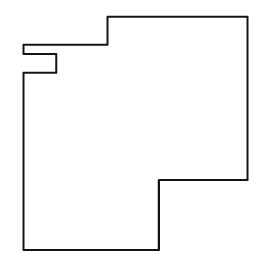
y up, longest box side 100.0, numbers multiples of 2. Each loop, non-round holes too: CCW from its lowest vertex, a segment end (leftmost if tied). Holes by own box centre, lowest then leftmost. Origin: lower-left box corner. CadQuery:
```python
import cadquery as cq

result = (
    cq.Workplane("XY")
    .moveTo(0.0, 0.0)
    .lineTo(58.0, 0.0)
    .lineTo(58.0, 30.0)
    .lineTo(96.0, 30.0)
    .lineTo(96.0, 100.0)
    .lineTo(36.0, 100.0)
    .lineTo(36.0, 88.0)
    .lineTo(0.0, 88.0)
    .lineTo(0.0, 84.0)
    .lineTo(14.0, 84.0)
    .lineTo(14.0, 76.0)
    .lineTo(0.0, 76.0)
    .close()
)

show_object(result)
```